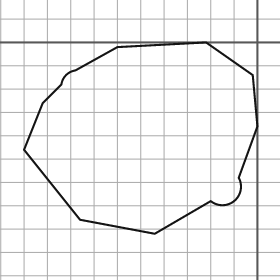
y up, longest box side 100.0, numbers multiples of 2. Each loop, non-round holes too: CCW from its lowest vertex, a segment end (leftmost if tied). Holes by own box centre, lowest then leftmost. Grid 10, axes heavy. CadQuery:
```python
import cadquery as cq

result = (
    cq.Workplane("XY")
    .moveTo(-44.0, -82.0)
    .lineTo(-20.0, -68.0)
    .threePointArc((-10.0, -68.0), (-8.0, -58.0))
    .lineTo(0.0, -36.0)
    .lineTo(-2.0, -14.0)
    .lineTo(-22.0, 0.0)
    .lineTo(-60.0, -2.0)
    .lineTo(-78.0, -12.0)
    .threePointArc((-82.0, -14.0), (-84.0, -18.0))
    .lineTo(-92.0, -26.0)
    .lineTo(-100.0, -46.0)
    .lineTo(-76.0, -76.0)
    .close()
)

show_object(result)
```